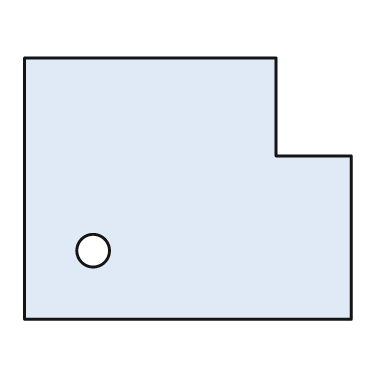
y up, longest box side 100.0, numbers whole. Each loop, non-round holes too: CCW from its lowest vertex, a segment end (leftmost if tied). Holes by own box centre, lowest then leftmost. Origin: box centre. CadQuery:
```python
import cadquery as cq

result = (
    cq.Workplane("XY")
    .moveTo(-50.0, -40.0)
    .lineTo(50.0, -40.0)
    .lineTo(50.0, 10.0)
    .lineTo(27.0, 10.0)
    .lineTo(27.0, 40.0)
    .lineTo(-50.0, 40.0)
    .close()
    .moveTo(-29.0, -19.0)
    .circle(5.0)
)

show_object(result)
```